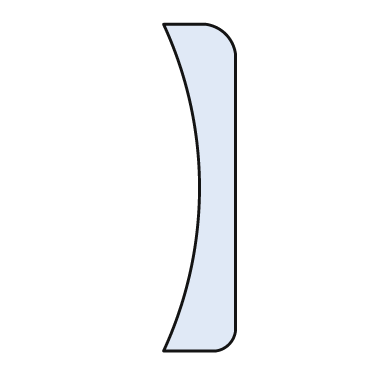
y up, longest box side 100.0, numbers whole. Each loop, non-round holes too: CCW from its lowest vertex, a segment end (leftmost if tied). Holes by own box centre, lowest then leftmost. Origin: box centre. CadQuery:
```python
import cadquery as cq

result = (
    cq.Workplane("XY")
    .moveTo(-11.0, -50.0)
    .lineTo(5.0, -50.0)
    .threePointArc((9.0, -48.0), (11.0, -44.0))
    .lineTo(11.0, 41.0)
    .threePointArc((8.0, 47.0), (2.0, 50.0))
    .lineTo(-11.0, 50.0)
    .threePointArc((0.0, 0.0), (-11.0, -50.0))
    .close()
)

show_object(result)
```